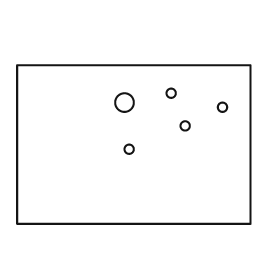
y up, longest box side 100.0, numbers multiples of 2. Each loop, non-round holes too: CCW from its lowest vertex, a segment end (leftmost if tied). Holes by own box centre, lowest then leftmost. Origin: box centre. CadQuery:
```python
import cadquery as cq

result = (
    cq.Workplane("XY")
    .moveTo(-50.0, -34.0)
    .lineTo(50.0, -34.0)
    .lineTo(50.0, 34.0)
    .lineTo(-50.0, 34.0)
    .close()
    .moveTo(-2.0, -2.0)
    .circle(2.0)
    .moveTo(22.0, 8.0)
    .circle(2.0)
    .moveTo(38.0, 16.0)
    .circle(2.0)
    .moveTo(-4.0, 18.0)
    .circle(4.0)
    .moveTo(16.0, 22.0)
    .circle(2.0)
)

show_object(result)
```